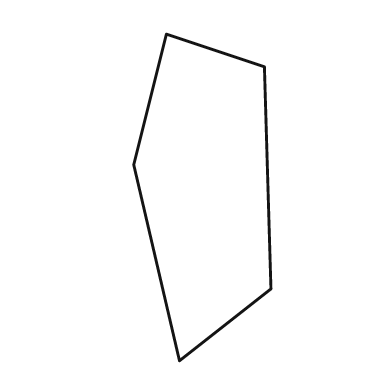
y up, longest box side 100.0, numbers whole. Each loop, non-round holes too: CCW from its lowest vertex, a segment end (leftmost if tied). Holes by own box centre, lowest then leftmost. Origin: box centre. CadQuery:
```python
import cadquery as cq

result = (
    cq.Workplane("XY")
    .moveTo(-7.0, -50.0)
    .lineTo(21.0, -28.0)
    .lineTo(19.0, 40.0)
    .lineTo(-11.0, 50.0)
    .lineTo(-21.0, 10.0)
    .close()
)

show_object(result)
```